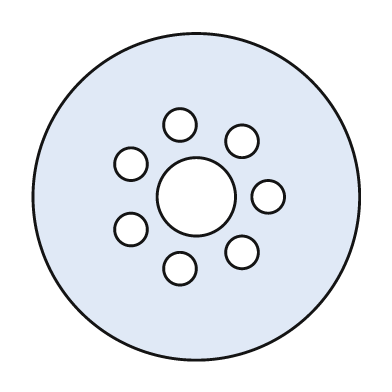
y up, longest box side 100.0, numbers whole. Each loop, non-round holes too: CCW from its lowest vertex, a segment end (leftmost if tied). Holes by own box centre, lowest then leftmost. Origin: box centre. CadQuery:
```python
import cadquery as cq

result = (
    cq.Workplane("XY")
    .moveTo(0.0, 0.0)
    .circle(50.0)
    .moveTo(-5.0, -22.0)
    .circle(5.0)
    .moveTo(14.0, -17.0)
    .circle(5.0)
    .moveTo(-20.0, -10.0)
    .circle(5.0)
    .moveTo(0.0, 0.0)
    .circle(12.0)
    .moveTo(22.0, 0.0)
    .circle(5.0)
    .moveTo(-20.0, 10.0)
    .circle(5.0)
    .moveTo(14.0, 17.0)
    .circle(5.0)
    .moveTo(-5.0, 22.0)
    .circle(5.0)
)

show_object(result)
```